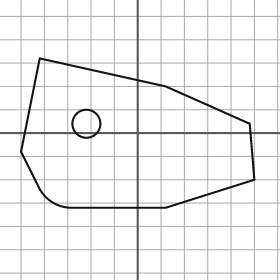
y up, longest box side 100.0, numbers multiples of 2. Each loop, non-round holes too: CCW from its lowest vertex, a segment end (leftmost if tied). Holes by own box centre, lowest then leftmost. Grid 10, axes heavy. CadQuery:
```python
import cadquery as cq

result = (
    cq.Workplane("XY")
    .moveTo(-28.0, -32.0)
    .lineTo(12.0, -32.0)
    .lineTo(50.0, -20.0)
    .lineTo(48.0, 4.0)
    .lineTo(12.0, 20.0)
    .lineTo(-42.0, 32.0)
    .lineTo(-50.0, -8.0)
    .lineTo(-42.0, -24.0)
    .threePointArc((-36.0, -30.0), (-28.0, -32.0))
    .close()
    .moveTo(-22.0, 4.0)
    .circle(6.0)
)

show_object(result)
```